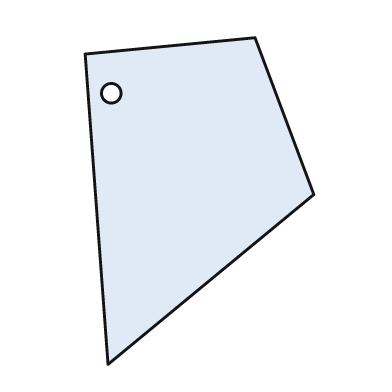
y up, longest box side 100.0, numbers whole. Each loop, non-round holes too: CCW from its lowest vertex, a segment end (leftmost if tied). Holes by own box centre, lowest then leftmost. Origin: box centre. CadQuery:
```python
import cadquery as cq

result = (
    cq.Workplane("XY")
    .moveTo(-28.0, -50.0)
    .lineTo(35.0, 2.0)
    .lineTo(17.0, 50.0)
    .lineTo(-35.0, 45.0)
    .close()
    .moveTo(-27.0, 33.0)
    .circle(3.0)
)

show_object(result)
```